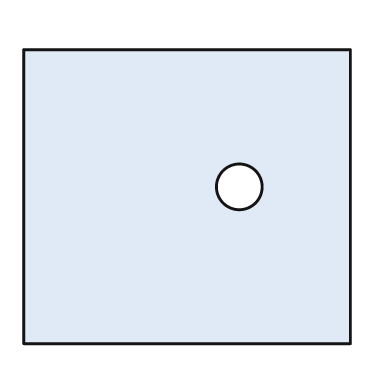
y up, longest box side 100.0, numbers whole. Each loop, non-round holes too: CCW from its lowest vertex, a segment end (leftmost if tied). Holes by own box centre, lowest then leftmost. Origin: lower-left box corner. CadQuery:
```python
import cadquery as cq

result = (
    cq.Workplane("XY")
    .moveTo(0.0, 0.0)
    .lineTo(100.0, 0.0)
    .lineTo(100.0, 90.0)
    .lineTo(0.0, 90.0)
    .close()
    .moveTo(66.0, 48.0)
    .circle(7.0)
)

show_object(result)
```